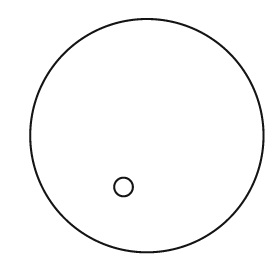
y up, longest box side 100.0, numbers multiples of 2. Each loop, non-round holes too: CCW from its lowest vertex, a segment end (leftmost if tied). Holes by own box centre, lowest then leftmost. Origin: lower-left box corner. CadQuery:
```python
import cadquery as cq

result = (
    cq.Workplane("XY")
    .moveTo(50.0, 50.0)
    .circle(50.0)
    .moveTo(40.0, 28.0)
    .circle(4.0)
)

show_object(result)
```